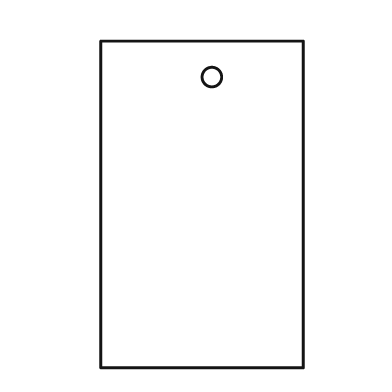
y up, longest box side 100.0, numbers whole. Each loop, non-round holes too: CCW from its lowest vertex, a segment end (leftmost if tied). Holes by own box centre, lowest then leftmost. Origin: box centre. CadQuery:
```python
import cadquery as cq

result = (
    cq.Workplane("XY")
    .moveTo(-31.0, -50.0)
    .lineTo(31.0, -50.0)
    .lineTo(31.0, 50.0)
    .lineTo(-31.0, 50.0)
    .close()
    .moveTo(3.0, 39.0)
    .circle(3.0)
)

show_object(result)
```